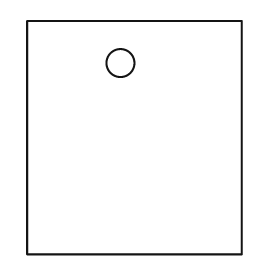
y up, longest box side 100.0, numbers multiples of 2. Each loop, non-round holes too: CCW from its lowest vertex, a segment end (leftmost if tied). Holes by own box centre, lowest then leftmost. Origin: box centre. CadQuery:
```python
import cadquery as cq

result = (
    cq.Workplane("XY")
    .moveTo(-46.0, -50.0)
    .lineTo(46.0, -50.0)
    .lineTo(46.0, 50.0)
    .lineTo(-46.0, 50.0)
    .close()
    .moveTo(-6.0, 32.0)
    .circle(6.0)
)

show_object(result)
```